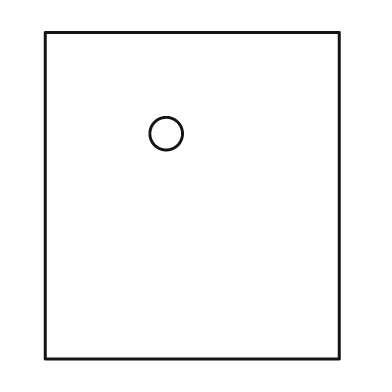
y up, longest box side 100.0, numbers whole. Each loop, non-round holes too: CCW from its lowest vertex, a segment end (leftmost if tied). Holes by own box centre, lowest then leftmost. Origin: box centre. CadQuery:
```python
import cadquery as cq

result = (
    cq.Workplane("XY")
    .moveTo(-45.0, -50.0)
    .lineTo(45.0, -50.0)
    .lineTo(45.0, 50.0)
    .lineTo(-45.0, 50.0)
    .close()
    .moveTo(-8.0, 19.0)
    .circle(5.0)
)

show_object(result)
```